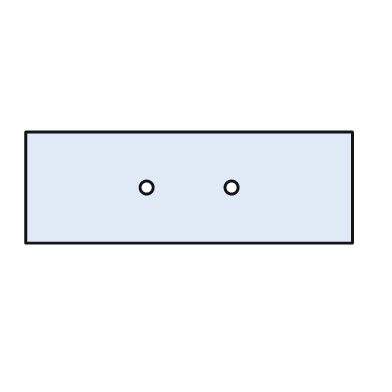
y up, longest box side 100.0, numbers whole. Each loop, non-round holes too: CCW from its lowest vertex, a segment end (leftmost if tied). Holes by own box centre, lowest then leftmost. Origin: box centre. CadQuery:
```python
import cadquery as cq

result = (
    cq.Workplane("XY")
    .moveTo(-50.0, -17.0)
    .lineTo(50.0, -17.0)
    .lineTo(50.0, 17.0)
    .lineTo(-50.0, 17.0)
    .close()
    .moveTo(-13.0, 0.0)
    .circle(2.0)
    .moveTo(13.0, 0.0)
    .circle(2.0)
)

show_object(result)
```